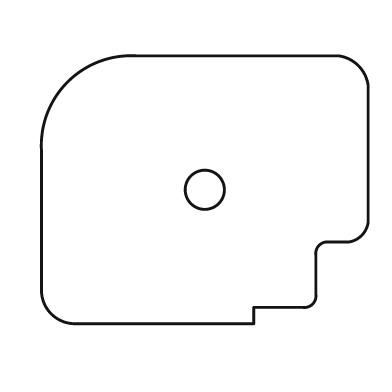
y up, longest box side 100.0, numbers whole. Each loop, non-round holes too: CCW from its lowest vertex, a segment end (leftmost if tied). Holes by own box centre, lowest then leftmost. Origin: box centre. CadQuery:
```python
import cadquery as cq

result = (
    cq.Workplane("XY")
    .moveTo(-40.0, -41.0)
    .lineTo(15.0, -41.0)
    .lineTo(15.0, -36.0)
    .lineTo(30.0, -36.0)
    .threePointArc((33.0, -35.0), (34.0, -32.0))
    .lineTo(34.0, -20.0)
    .threePointArc((35.0, -17.0), (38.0, -16.0))
    .lineTo(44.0, -16.0)
    .threePointArc((48.0, -14.0), (50.0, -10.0))
    .lineTo(50.0, 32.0)
    .threePointArc((47.0, 38.0), (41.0, 41.0))
    .lineTo(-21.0, 41.0)
    .threePointArc((-42.0, 33.0), (-50.0, 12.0))
    .lineTo(-50.0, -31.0)
    .threePointArc((-47.0, -38.0), (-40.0, -41.0))
    .close()
    .moveTo(0.0, 0.0)
    .circle(6.0)
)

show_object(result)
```